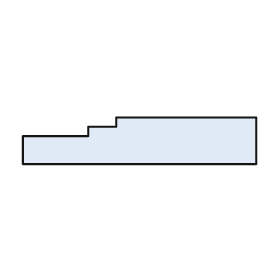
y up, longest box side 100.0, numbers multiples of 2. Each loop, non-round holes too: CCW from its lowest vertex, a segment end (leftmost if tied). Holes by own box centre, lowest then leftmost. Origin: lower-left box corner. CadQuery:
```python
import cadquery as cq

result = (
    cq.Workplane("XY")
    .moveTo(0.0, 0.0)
    .lineTo(100.0, 0.0)
    .lineTo(100.0, 20.0)
    .lineTo(40.0, 20.0)
    .lineTo(40.0, 16.0)
    .lineTo(28.0, 16.0)
    .lineTo(28.0, 12.0)
    .lineTo(0.0, 12.0)
    .close()
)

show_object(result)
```